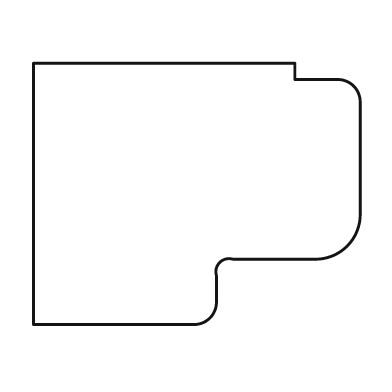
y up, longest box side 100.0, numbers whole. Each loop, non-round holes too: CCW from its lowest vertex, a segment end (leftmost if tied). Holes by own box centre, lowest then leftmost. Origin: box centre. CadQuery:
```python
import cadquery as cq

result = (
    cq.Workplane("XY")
    .moveTo(-50.0, -40.0)
    .lineTo(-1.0, -40.0)
    .threePointArc((4.0, -38.0), (6.0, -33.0))
    .lineTo(6.0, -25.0)
    .threePointArc((7.0, -21.0), (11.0, -20.0))
    .lineTo(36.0, -20.0)
    .threePointArc((46.0, -16.0), (50.0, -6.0))
    .lineTo(50.0, 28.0)
    .threePointArc((48.0, 33.0), (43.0, 35.0))
    .lineTo(30.0, 35.0)
    .lineTo(30.0, 40.0)
    .lineTo(-50.0, 40.0)
    .close()
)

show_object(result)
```